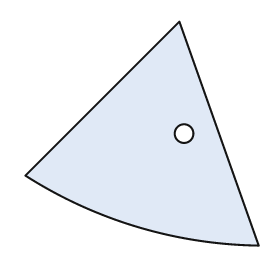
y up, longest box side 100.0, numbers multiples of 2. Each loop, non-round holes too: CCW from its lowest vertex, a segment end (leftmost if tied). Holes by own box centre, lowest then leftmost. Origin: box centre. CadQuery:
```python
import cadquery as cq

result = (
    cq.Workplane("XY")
    .moveTo(50.0, -48.0)
    .lineTo(16.0, 48.0)
    .lineTo(-50.0, -18.0)
    .threePointArc((-2.0, -40.0), (50.0, -48.0))
    .close()
    .moveTo(18.0, 0.0)
    .circle(4.0)
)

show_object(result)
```